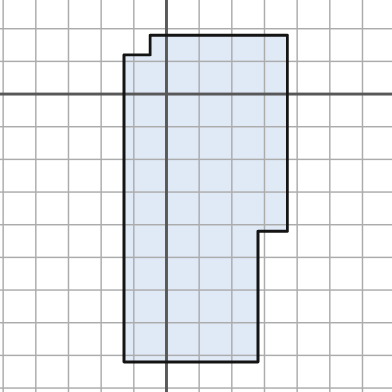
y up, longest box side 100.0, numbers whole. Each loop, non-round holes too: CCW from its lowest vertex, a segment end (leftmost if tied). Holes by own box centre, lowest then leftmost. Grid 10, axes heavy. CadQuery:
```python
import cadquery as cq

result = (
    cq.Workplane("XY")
    .moveTo(-13.0, -82.0)
    .lineTo(28.0, -82.0)
    .lineTo(28.0, -42.0)
    .lineTo(37.0, -42.0)
    .lineTo(37.0, 18.0)
    .lineTo(-5.0, 18.0)
    .lineTo(-5.0, 12.0)
    .lineTo(-13.0, 12.0)
    .close()
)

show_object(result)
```